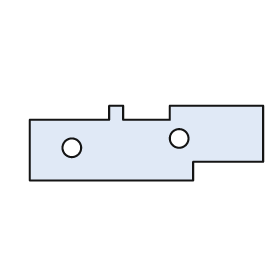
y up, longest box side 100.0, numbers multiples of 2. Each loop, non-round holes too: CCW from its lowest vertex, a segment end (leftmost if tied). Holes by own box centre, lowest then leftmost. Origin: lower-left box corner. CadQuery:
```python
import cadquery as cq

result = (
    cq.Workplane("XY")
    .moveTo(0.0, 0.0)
    .lineTo(70.0, 0.0)
    .lineTo(70.0, 8.0)
    .lineTo(100.0, 8.0)
    .lineTo(100.0, 32.0)
    .lineTo(60.0, 32.0)
    .lineTo(60.0, 26.0)
    .lineTo(40.0, 26.0)
    .lineTo(40.0, 32.0)
    .lineTo(34.0, 32.0)
    .lineTo(34.0, 26.0)
    .lineTo(0.0, 26.0)
    .close()
    .moveTo(18.0, 14.0)
    .circle(4.0)
    .moveTo(64.0, 18.0)
    .circle(4.0)
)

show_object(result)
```